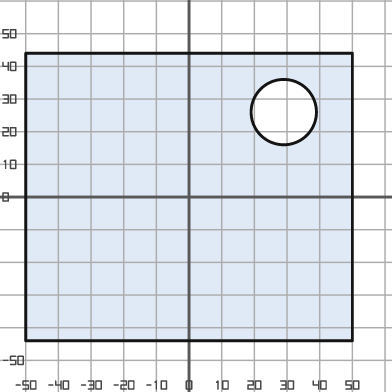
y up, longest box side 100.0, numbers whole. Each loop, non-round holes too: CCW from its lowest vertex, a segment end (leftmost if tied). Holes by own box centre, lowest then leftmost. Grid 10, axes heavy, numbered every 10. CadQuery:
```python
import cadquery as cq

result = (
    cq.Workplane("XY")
    .moveTo(-50.0, -44.0)
    .lineTo(50.0, -44.0)
    .lineTo(50.0, 44.0)
    .lineTo(-50.0, 44.0)
    .close()
    .moveTo(29.0, 26.0)
    .circle(10.0)
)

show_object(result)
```